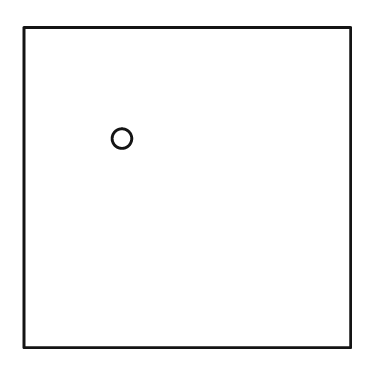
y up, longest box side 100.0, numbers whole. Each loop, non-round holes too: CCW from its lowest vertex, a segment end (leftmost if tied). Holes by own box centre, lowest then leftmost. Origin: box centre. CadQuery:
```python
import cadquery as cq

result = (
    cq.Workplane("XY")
    .moveTo(-50.0, -49.0)
    .lineTo(50.0, -49.0)
    .lineTo(50.0, 49.0)
    .lineTo(-50.0, 49.0)
    .close()
    .moveTo(-20.0, 15.0)
    .circle(3.0)
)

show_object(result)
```